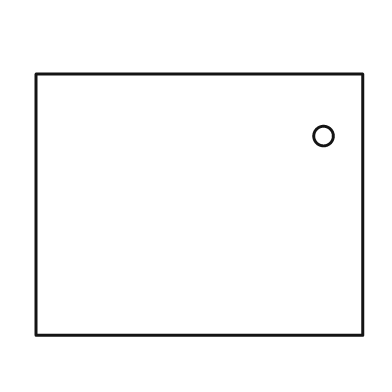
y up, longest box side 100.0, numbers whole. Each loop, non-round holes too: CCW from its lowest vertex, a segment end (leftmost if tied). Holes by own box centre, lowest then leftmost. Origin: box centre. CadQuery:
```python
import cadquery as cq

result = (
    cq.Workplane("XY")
    .moveTo(-50.0, -40.0)
    .lineTo(50.0, -40.0)
    .lineTo(50.0, 40.0)
    .lineTo(-50.0, 40.0)
    .close()
    .moveTo(38.0, 21.0)
    .circle(3.0)
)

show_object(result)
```